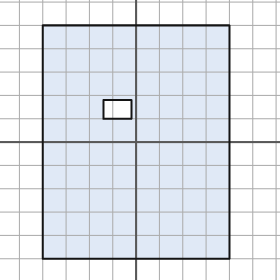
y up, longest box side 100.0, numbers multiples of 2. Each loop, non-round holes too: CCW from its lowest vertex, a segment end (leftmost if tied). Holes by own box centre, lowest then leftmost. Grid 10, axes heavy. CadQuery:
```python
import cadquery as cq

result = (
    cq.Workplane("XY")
    .moveTo(-40.0, -50.0)
    .lineTo(40.0, -50.0)
    .lineTo(40.0, 50.0)
    .lineTo(-40.0, 50.0)
    .close()
    .moveTo(-14.0, 10.0)
    .lineTo(-2.0, 10.0)
    .lineTo(-2.0, 18.0)
    .lineTo(-14.0, 18.0)
    .close()
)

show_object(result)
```